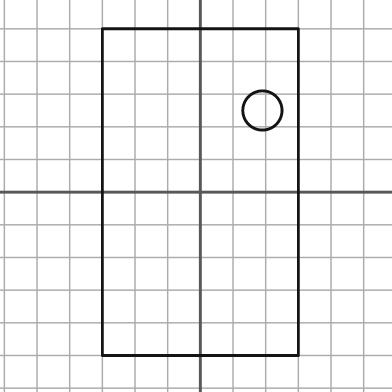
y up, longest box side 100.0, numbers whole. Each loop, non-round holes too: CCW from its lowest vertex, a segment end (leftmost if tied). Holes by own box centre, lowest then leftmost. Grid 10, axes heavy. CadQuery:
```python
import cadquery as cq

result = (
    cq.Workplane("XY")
    .moveTo(-30.0, -50.0)
    .lineTo(30.0, -50.0)
    .lineTo(30.0, 50.0)
    .lineTo(-30.0, 50.0)
    .close()
    .moveTo(19.0, 25.0)
    .circle(6.0)
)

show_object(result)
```